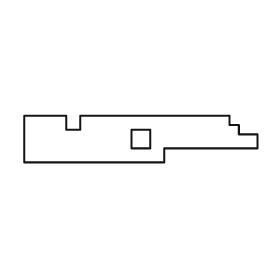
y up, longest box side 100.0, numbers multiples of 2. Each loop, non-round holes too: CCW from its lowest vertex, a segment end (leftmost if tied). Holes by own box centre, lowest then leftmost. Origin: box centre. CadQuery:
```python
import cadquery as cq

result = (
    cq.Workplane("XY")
    .moveTo(-50.0, -10.0)
    .lineTo(10.0, -10.0)
    .lineTo(10.0, -4.0)
    .lineTo(50.0, -4.0)
    .lineTo(50.0, 2.0)
    .lineTo(42.0, 2.0)
    .lineTo(42.0, 6.0)
    .lineTo(38.0, 6.0)
    .lineTo(38.0, 10.0)
    .lineTo(-26.0, 10.0)
    .lineTo(-26.0, 4.0)
    .lineTo(-32.0, 4.0)
    .lineTo(-32.0, 10.0)
    .lineTo(-50.0, 10.0)
    .close()
    .moveTo(-4.0, -4.0)
    .lineTo(4.0, -4.0)
    .lineTo(4.0, 4.0)
    .lineTo(-4.0, 4.0)
    .close()
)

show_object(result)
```